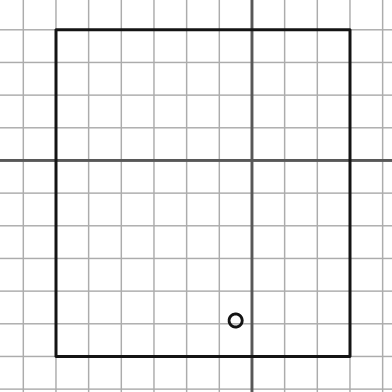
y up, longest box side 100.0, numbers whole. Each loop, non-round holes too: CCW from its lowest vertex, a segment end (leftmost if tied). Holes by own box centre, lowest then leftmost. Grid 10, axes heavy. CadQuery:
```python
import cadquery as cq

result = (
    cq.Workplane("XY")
    .moveTo(-60.0, -60.0)
    .lineTo(30.0, -60.0)
    .lineTo(30.0, 40.0)
    .lineTo(-60.0, 40.0)
    .close()
    .moveTo(-5.0, -49.0)
    .circle(2.0)
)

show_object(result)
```